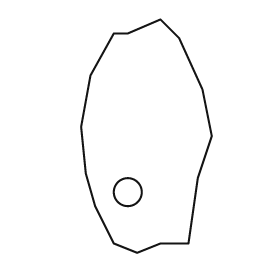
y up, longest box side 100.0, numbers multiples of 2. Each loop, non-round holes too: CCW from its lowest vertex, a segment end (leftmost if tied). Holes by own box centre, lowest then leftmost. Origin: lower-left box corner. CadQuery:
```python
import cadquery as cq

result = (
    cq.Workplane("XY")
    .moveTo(24.0, 0.0)
    .lineTo(34.0, 4.0)
    .lineTo(46.0, 4.0)
    .lineTo(50.0, 32.0)
    .lineTo(56.0, 50.0)
    .lineTo(52.0, 70.0)
    .lineTo(42.0, 92.0)
    .lineTo(34.0, 100.0)
    .lineTo(20.0, 94.0)
    .lineTo(14.0, 94.0)
    .lineTo(4.0, 76.0)
    .lineTo(0.0, 54.0)
    .lineTo(2.0, 34.0)
    .lineTo(6.0, 20.0)
    .lineTo(14.0, 4.0)
    .close()
    .moveTo(20.0, 26.0)
    .circle(6.0)
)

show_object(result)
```